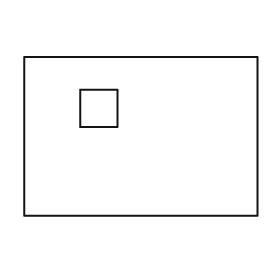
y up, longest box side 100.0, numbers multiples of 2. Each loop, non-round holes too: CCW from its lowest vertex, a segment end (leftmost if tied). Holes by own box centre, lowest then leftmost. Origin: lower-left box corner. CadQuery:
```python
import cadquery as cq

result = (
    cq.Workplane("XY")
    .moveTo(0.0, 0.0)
    .lineTo(100.0, 0.0)
    .lineTo(100.0, 68.0)
    .lineTo(0.0, 68.0)
    .close()
    .moveTo(24.0, 38.0)
    .lineTo(40.0, 38.0)
    .lineTo(40.0, 54.0)
    .lineTo(24.0, 54.0)
    .close()
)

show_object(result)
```